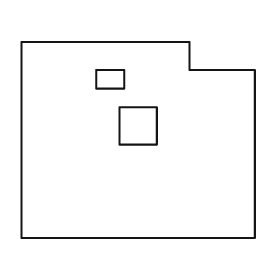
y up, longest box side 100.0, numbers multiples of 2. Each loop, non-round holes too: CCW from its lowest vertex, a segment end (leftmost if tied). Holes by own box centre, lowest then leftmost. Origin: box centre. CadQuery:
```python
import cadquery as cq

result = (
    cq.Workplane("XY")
    .moveTo(-50.0, -42.0)
    .lineTo(50.0, -42.0)
    .lineTo(50.0, 30.0)
    .lineTo(22.0, 30.0)
    .lineTo(22.0, 42.0)
    .lineTo(-50.0, 42.0)
    .close()
    .moveTo(-8.0, -2.0)
    .lineTo(8.0, -2.0)
    .lineTo(8.0, 14.0)
    .lineTo(-8.0, 14.0)
    .close()
    .moveTo(-18.0, 22.0)
    .lineTo(-6.0, 22.0)
    .lineTo(-6.0, 30.0)
    .lineTo(-18.0, 30.0)
    .close()
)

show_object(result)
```